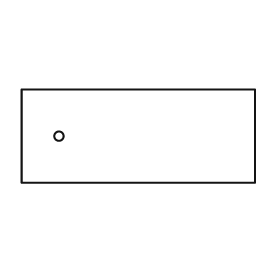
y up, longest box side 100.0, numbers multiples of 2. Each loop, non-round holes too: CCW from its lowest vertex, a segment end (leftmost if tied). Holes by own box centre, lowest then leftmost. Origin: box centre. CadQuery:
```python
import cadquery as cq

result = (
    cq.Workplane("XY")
    .moveTo(-50.0, -20.0)
    .lineTo(50.0, -20.0)
    .lineTo(50.0, 20.0)
    .lineTo(-50.0, 20.0)
    .close()
    .moveTo(-34.0, 0.0)
    .circle(2.0)
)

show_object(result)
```